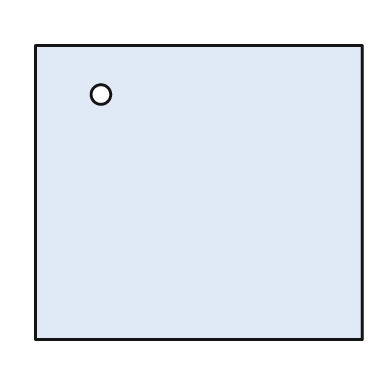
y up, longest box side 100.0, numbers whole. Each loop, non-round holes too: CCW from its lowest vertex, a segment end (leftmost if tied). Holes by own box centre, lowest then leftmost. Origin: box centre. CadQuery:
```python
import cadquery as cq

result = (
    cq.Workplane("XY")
    .moveTo(-50.0, -45.0)
    .lineTo(50.0, -45.0)
    .lineTo(50.0, 45.0)
    .lineTo(-50.0, 45.0)
    .close()
    .moveTo(-30.0, 30.0)
    .circle(3.0)
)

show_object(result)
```